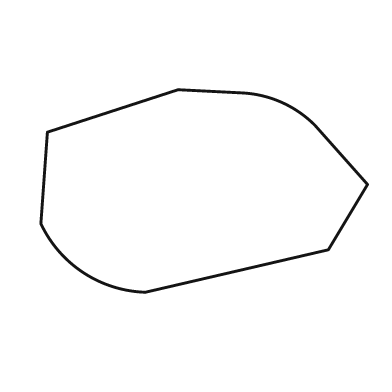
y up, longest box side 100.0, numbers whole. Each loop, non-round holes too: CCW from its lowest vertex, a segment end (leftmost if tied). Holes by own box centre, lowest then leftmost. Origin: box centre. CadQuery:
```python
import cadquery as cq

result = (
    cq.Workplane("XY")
    .moveTo(-18.0, -31.0)
    .lineTo(38.0, -18.0)
    .lineTo(50.0, 2.0)
    .lineTo(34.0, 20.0)
    .threePointArc((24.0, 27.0), (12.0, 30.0))
    .lineTo(-8.0, 31.0)
    .lineTo(-48.0, 18.0)
    .lineTo(-50.0, -10.0)
    .threePointArc((-37.0, -25.0), (-18.0, -31.0))
    .close()
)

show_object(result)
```